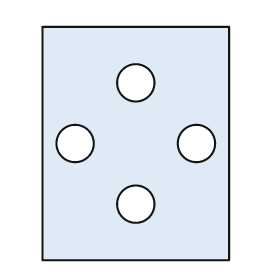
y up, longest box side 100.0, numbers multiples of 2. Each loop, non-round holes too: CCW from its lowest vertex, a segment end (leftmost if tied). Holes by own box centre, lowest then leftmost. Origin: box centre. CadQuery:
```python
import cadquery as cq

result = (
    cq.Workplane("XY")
    .moveTo(-40.0, -50.0)
    .lineTo(40.0, -50.0)
    .lineTo(40.0, 50.0)
    .lineTo(-40.0, 50.0)
    .close()
    .moveTo(0.0, -26.0)
    .circle(8.0)
    .moveTo(-26.0, 0.0)
    .circle(8.0)
    .moveTo(26.0, 0.0)
    .circle(8.0)
    .moveTo(0.0, 26.0)
    .circle(8.0)
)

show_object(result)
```